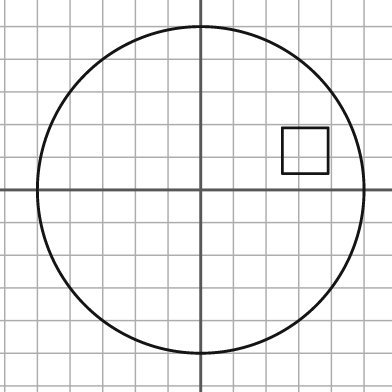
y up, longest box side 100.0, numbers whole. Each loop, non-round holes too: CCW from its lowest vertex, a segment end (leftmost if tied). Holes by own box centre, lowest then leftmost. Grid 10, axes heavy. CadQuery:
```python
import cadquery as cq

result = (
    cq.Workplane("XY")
    .moveTo(0.0, 0.0)
    .circle(50.0)
    .moveTo(25.0, 5.0)
    .lineTo(39.0, 5.0)
    .lineTo(39.0, 19.0)
    .lineTo(25.0, 19.0)
    .close()
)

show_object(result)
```